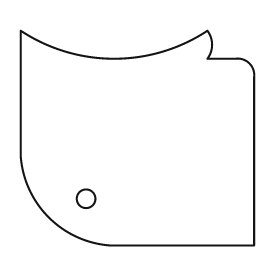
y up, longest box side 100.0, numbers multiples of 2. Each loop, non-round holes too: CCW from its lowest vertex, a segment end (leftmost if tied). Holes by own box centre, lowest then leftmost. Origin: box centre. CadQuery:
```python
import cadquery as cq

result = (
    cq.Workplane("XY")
    .moveTo(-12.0, -46.0)
    .lineTo(50.0, -46.0)
    .lineTo(50.0, 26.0)
    .threePointArc((48.0, 32.0), (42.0, 34.0))
    .lineTo(30.0, 34.0)
    .threePointArc((32.0, 40.0), (30.0, 46.0))
    .threePointArc((-10.0, 34.0), (-50.0, 46.0))
    .lineTo(-50.0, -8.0)
    .threePointArc((-38.0, -34.0), (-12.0, -46.0))
    .close()
    .moveTo(-22.0, -26.0)
    .circle(4.0)
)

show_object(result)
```